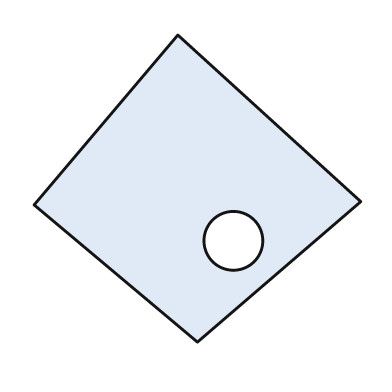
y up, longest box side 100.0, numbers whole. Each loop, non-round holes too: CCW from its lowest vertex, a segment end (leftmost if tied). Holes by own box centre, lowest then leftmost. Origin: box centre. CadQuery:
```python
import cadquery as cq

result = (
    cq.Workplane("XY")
    .moveTo(0.0, -47.0)
    .lineTo(50.0, -4.0)
    .lineTo(-6.0, 47.0)
    .lineTo(-50.0, -5.0)
    .close()
    .moveTo(11.0, -16.0)
    .circle(9.0)
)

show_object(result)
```